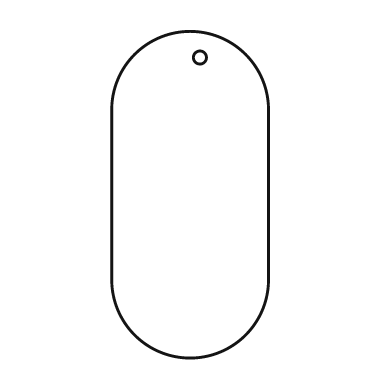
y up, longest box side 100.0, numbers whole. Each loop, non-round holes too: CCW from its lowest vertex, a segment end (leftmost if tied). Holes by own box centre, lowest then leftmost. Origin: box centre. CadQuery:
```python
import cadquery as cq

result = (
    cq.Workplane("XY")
    .moveTo(-24.0, -26.0)
    .threePointArc((0.0, -50.0), (24.0, -26.0))
    .lineTo(24.0, 26.0)
    .threePointArc((0.0, 50.0), (-24.0, 26.0))
    .close()
    .moveTo(3.0, 42.0)
    .circle(2.0)
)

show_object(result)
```